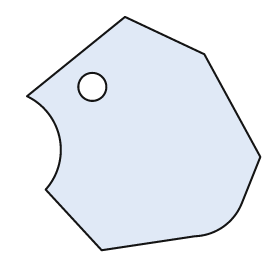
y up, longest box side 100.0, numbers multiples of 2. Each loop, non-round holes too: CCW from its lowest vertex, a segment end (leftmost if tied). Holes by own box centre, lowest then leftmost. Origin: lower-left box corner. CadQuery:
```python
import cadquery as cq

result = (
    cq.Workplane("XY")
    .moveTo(32.0, 0.0)
    .lineTo(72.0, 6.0)
    .threePointArc((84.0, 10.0), (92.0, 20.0))
    .lineTo(100.0, 40.0)
    .lineTo(76.0, 84.0)
    .lineTo(42.0, 100.0)
    .lineTo(0.0, 66.0)
    .threePointArc((14.0, 48.0), (8.0, 26.0))
    .close()
    .moveTo(28.0, 70.0)
    .circle(6.0)
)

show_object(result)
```